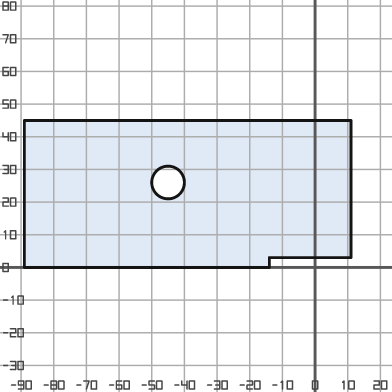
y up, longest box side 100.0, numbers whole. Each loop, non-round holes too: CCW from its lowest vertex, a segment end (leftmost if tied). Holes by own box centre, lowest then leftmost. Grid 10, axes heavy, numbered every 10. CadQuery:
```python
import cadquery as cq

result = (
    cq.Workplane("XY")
    .moveTo(-89.0, 0.0)
    .lineTo(-14.0, 0.0)
    .lineTo(-14.0, 3.0)
    .lineTo(11.0, 3.0)
    .lineTo(11.0, 45.0)
    .lineTo(-89.0, 45.0)
    .close()
    .moveTo(-45.0, 26.0)
    .circle(5.0)
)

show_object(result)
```